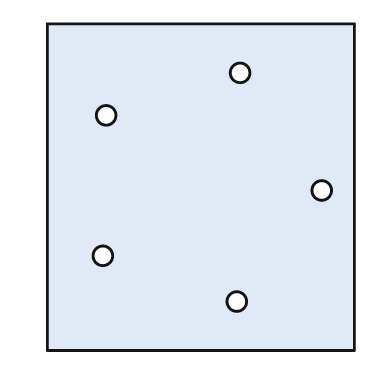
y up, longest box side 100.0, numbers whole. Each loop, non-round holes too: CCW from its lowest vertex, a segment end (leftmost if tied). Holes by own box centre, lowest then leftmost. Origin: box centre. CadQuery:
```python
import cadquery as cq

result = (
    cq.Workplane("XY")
    .moveTo(-47.0, -50.0)
    .lineTo(47.0, -50.0)
    .lineTo(47.0, 50.0)
    .lineTo(-47.0, 50.0)
    .close()
    .moveTo(11.0, -35.0)
    .circle(3.0)
    .moveTo(-30.0, -21.0)
    .circle(3.0)
    .moveTo(37.0, -1.0)
    .circle(3.0)
    .moveTo(-29.0, 22.0)
    .circle(3.0)
    .moveTo(12.0, 35.0)
    .circle(3.0)
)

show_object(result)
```